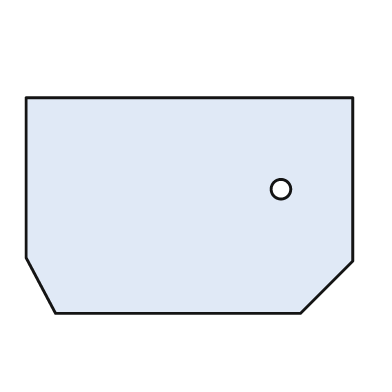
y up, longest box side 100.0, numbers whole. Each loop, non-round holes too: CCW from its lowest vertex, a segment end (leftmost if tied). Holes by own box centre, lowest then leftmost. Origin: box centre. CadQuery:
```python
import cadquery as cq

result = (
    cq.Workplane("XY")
    .moveTo(-41.0, -33.0)
    .lineTo(34.0, -33.0)
    .lineTo(50.0, -17.0)
    .lineTo(50.0, 33.0)
    .lineTo(-50.0, 33.0)
    .lineTo(-50.0, -16.0)
    .close()
    .moveTo(28.0, 5.0)
    .circle(3.0)
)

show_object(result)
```